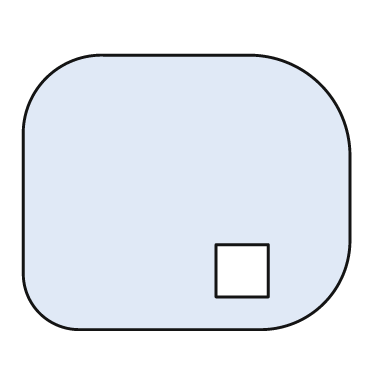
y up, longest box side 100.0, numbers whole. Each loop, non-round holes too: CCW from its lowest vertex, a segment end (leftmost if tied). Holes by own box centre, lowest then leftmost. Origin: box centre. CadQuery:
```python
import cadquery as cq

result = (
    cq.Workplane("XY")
    .moveTo(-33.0, -42.0)
    .lineTo(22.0, -42.0)
    .threePointArc((42.0, -34.0), (50.0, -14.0))
    .lineTo(50.0, 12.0)
    .threePointArc((41.0, 33.0), (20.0, 42.0))
    .lineTo(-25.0, 42.0)
    .threePointArc((-43.0, 35.0), (-50.0, 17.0))
    .lineTo(-50.0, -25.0)
    .threePointArc((-45.0, -37.0), (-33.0, -42.0))
    .close()
    .moveTo(9.0, -32.0)
    .lineTo(25.0, -32.0)
    .lineTo(25.0, -16.0)
    .lineTo(9.0, -16.0)
    .close()
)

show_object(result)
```